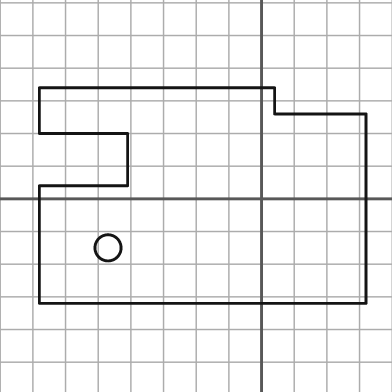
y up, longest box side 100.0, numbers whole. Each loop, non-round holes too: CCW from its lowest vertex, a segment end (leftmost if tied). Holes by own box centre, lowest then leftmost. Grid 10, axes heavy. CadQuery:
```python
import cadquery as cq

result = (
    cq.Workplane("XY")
    .moveTo(-68.0, -32.0)
    .lineTo(32.0, -32.0)
    .lineTo(32.0, 26.0)
    .lineTo(4.0, 26.0)
    .lineTo(4.0, 34.0)
    .lineTo(-68.0, 34.0)
    .lineTo(-68.0, 20.0)
    .lineTo(-41.0, 20.0)
    .lineTo(-41.0, 4.0)
    .lineTo(-68.0, 4.0)
    .close()
    .moveTo(-47.0, -15.0)
    .circle(4.0)
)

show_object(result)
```